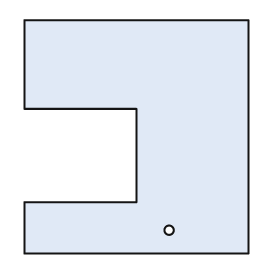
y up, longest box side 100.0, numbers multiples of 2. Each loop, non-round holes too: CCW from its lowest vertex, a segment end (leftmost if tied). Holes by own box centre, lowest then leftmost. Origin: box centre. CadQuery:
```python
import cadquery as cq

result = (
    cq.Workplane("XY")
    .moveTo(-48.0, -50.0)
    .lineTo(48.0, -50.0)
    .lineTo(48.0, 50.0)
    .lineTo(-48.0, 50.0)
    .lineTo(-48.0, 12.0)
    .lineTo(0.0, 12.0)
    .lineTo(0.0, -28.0)
    .lineTo(-48.0, -28.0)
    .close()
    .moveTo(14.0, -40.0)
    .circle(2.0)
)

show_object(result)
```